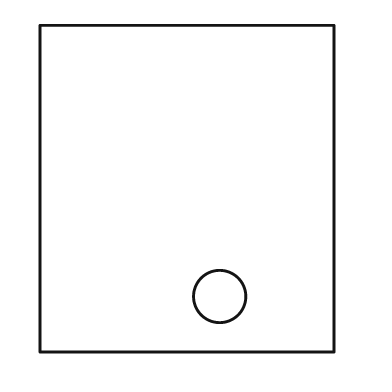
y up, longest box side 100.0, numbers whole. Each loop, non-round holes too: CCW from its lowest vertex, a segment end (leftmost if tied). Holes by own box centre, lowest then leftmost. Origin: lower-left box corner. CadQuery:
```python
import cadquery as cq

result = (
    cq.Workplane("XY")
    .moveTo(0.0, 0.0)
    .lineTo(90.0, 0.0)
    .lineTo(90.0, 100.0)
    .lineTo(0.0, 100.0)
    .close()
    .moveTo(55.0, 17.0)
    .circle(8.0)
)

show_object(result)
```